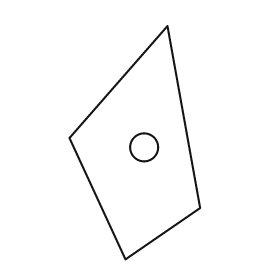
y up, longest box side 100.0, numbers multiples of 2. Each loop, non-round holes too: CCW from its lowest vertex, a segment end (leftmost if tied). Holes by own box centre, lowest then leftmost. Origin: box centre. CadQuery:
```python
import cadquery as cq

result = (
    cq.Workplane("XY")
    .moveTo(-4.0, -50.0)
    .lineTo(28.0, -28.0)
    .lineTo(14.0, 50.0)
    .lineTo(-28.0, 2.0)
    .close()
    .moveTo(4.0, -2.0)
    .circle(6.0)
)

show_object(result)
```